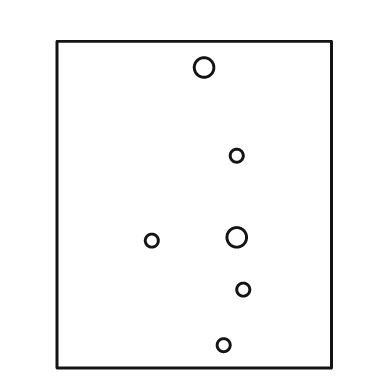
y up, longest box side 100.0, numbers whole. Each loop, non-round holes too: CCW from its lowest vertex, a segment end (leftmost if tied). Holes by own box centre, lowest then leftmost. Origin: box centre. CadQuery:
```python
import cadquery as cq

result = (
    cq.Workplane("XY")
    .moveTo(-42.0, -50.0)
    .lineTo(42.0, -50.0)
    .lineTo(42.0, 50.0)
    .lineTo(-42.0, 50.0)
    .close()
    .moveTo(9.0, -43.0)
    .circle(2.0)
    .moveTo(15.0, -26.0)
    .circle(2.0)
    .moveTo(-13.0, -11.0)
    .circle(2.0)
    .moveTo(13.0, -10.0)
    .circle(3.0)
    .moveTo(13.0, 15.0)
    .circle(2.0)
    .moveTo(3.0, 42.0)
    .circle(3.0)
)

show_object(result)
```